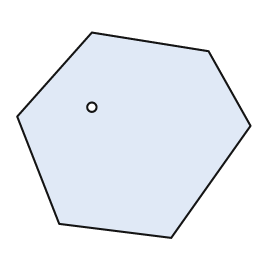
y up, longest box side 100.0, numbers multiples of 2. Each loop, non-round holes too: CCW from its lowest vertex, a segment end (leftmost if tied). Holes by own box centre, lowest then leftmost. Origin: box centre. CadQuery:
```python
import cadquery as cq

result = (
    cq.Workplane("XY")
    .moveTo(16.0, -44.0)
    .lineTo(50.0, 4.0)
    .lineTo(32.0, 36.0)
    .lineTo(-18.0, 44.0)
    .lineTo(-50.0, 8.0)
    .lineTo(-32.0, -38.0)
    .close()
    .moveTo(-18.0, 12.0)
    .circle(2.0)
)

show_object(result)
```